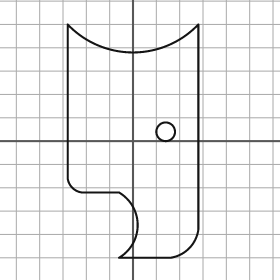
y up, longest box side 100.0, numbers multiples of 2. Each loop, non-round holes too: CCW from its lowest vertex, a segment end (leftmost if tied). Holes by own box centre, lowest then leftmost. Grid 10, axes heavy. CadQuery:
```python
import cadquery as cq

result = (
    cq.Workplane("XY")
    .moveTo(-6.0, -50.0)
    .lineTo(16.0, -50.0)
    .threePointArc((24.0, -46.0), (28.0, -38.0))
    .lineTo(28.0, 50.0)
    .threePointArc((0.0, 38.0), (-28.0, 50.0))
    .lineTo(-28.0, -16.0)
    .threePointArc((-26.0, -20.0), (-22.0, -22.0))
    .lineTo(-6.0, -22.0)
    .threePointArc((2.0, -36.0), (-6.0, -50.0))
    .close()
    .moveTo(14.0, 4.0)
    .circle(4.0)
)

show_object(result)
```